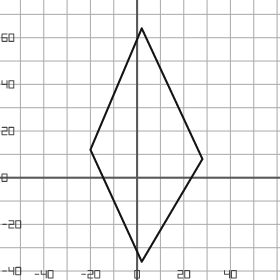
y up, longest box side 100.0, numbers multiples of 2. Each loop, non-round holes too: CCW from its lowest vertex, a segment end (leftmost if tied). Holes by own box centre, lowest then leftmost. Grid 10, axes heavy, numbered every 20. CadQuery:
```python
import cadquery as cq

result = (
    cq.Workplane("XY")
    .moveTo(2.0, -36.0)
    .lineTo(28.0, 8.0)
    .lineTo(2.0, 64.0)
    .lineTo(-20.0, 12.0)
    .close()
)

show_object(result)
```